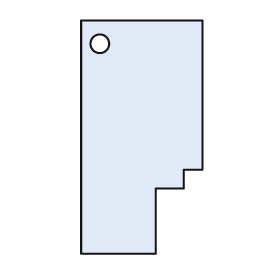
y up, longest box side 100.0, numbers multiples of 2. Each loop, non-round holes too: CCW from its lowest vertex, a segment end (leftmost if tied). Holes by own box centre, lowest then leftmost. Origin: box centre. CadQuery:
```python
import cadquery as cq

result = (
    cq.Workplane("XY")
    .moveTo(-26.0, -50.0)
    .lineTo(6.0, -50.0)
    .lineTo(6.0, -22.0)
    .lineTo(18.0, -22.0)
    .lineTo(18.0, -14.0)
    .lineTo(26.0, -14.0)
    .lineTo(26.0, 50.0)
    .lineTo(-26.0, 50.0)
    .close()
    .moveTo(-18.0, 40.0)
    .circle(4.0)
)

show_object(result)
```